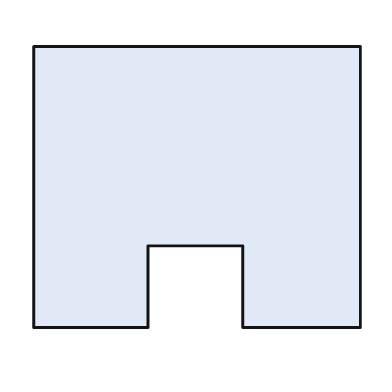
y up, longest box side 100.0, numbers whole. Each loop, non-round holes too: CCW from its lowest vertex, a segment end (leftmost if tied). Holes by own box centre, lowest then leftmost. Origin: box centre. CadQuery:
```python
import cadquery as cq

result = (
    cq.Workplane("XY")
    .moveTo(-50.0, -43.0)
    .lineTo(-15.0, -43.0)
    .lineTo(-15.0, -18.0)
    .lineTo(14.0, -18.0)
    .lineTo(14.0, -43.0)
    .lineTo(50.0, -43.0)
    .lineTo(50.0, 43.0)
    .lineTo(-50.0, 43.0)
    .close()
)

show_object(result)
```